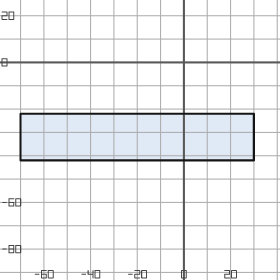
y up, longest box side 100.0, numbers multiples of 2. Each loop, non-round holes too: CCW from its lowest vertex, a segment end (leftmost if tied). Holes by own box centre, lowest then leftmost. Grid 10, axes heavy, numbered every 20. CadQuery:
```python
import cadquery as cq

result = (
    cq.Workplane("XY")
    .moveTo(-70.0, -42.0)
    .lineTo(30.0, -42.0)
    .lineTo(30.0, -22.0)
    .lineTo(-70.0, -22.0)
    .close()
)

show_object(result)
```